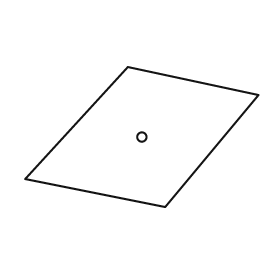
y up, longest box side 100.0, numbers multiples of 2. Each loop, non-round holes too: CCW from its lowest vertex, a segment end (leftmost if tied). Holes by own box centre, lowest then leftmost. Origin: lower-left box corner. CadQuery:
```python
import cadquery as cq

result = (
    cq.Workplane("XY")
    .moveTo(60.0, 0.0)
    .lineTo(100.0, 48.0)
    .lineTo(44.0, 60.0)
    .lineTo(0.0, 12.0)
    .close()
    .moveTo(50.0, 30.0)
    .circle(2.0)
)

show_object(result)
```